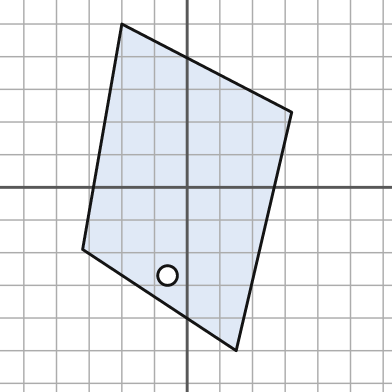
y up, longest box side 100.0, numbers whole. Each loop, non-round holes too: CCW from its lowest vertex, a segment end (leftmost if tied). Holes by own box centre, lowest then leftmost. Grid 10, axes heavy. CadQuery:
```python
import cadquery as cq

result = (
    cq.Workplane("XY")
    .moveTo(15.0, -50.0)
    .lineTo(32.0, 23.0)
    .lineTo(-20.0, 50.0)
    .lineTo(-32.0, -19.0)
    .close()
    .moveTo(-6.0, -27.0)
    .circle(3.0)
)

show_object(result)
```